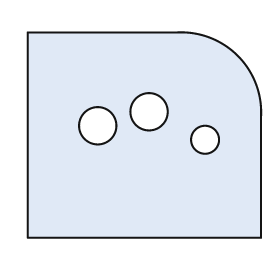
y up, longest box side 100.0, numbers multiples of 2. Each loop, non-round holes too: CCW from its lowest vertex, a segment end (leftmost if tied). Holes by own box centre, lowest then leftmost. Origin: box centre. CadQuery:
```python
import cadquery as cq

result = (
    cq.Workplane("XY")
    .moveTo(-50.0, -44.0)
    .lineTo(50.0, -44.0)
    .lineTo(50.0, 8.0)
    .threePointArc((40.0, 34.0), (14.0, 44.0))
    .lineTo(-50.0, 44.0)
    .close()
    .moveTo(26.0, -2.0)
    .circle(6.0)
    .moveTo(-20.0, 4.0)
    .circle(8.0)
    .moveTo(2.0, 10.0)
    .circle(8.0)
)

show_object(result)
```